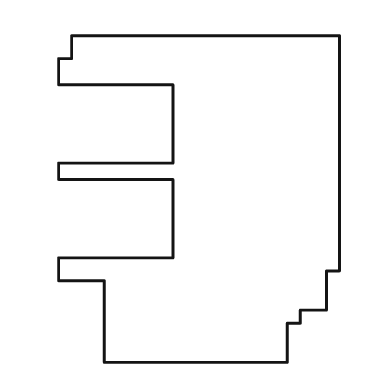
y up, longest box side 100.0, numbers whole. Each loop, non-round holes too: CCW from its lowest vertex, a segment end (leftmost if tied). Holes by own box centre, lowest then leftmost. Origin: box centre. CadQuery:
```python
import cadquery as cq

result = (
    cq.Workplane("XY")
    .moveTo(-29.0, -50.0)
    .lineTo(27.0, -50.0)
    .lineTo(27.0, -38.0)
    .lineTo(31.0, -38.0)
    .lineTo(31.0, -34.0)
    .lineTo(39.0, -34.0)
    .lineTo(39.0, -22.0)
    .lineTo(43.0, -22.0)
    .lineTo(43.0, 50.0)
    .lineTo(-39.0, 50.0)
    .lineTo(-39.0, 43.0)
    .lineTo(-43.0, 43.0)
    .lineTo(-43.0, 35.0)
    .lineTo(-8.0, 35.0)
    .lineTo(-8.0, 11.0)
    .lineTo(-43.0, 11.0)
    .lineTo(-43.0, 6.0)
    .lineTo(-8.0, 6.0)
    .lineTo(-8.0, -18.0)
    .lineTo(-43.0, -18.0)
    .lineTo(-43.0, -25.0)
    .lineTo(-29.0, -25.0)
    .close()
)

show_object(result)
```